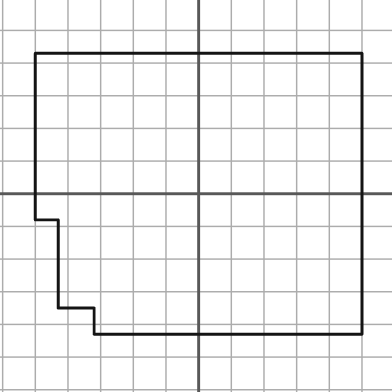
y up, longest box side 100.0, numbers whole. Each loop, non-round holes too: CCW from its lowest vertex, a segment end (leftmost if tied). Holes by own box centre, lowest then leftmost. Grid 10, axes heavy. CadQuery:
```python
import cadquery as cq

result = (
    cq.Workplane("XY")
    .moveTo(-32.0, -43.0)
    .lineTo(50.0, -43.0)
    .lineTo(50.0, 43.0)
    .lineTo(-50.0, 43.0)
    .lineTo(-50.0, -8.0)
    .lineTo(-43.0, -8.0)
    .lineTo(-43.0, -35.0)
    .lineTo(-32.0, -35.0)
    .close()
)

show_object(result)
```